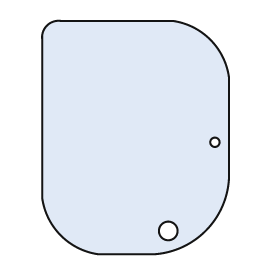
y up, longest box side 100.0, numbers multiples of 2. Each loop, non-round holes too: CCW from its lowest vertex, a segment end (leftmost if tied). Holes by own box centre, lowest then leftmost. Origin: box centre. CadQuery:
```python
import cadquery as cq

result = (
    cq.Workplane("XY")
    .moveTo(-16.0, -50.0)
    .lineTo(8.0, -50.0)
    .threePointArc((30.0, -40.0), (40.0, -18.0))
    .lineTo(40.0, 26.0)
    .threePointArc((32.0, 42.0), (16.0, 50.0))
    .lineTo(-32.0, 50.0)
    .threePointArc((-38.0, 48.0), (-40.0, 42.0))
    .lineTo(-40.0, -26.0)
    .threePointArc((-32.0, -42.0), (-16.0, -50.0))
    .close()
    .moveTo(14.0, -40.0)
    .circle(4.0)
    .moveTo(34.0, -2.0)
    .circle(2.0)
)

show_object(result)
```